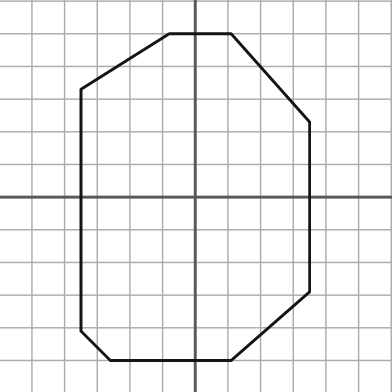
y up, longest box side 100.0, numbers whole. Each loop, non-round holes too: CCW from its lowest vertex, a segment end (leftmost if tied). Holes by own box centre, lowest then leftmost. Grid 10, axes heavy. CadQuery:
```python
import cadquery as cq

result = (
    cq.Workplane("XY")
    .moveTo(-26.0, -50.0)
    .lineTo(11.0, -50.0)
    .lineTo(35.0, -29.0)
    .lineTo(35.0, 23.0)
    .lineTo(11.0, 50.0)
    .lineTo(-8.0, 50.0)
    .lineTo(-35.0, 33.0)
    .lineTo(-35.0, -41.0)
    .close()
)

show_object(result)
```